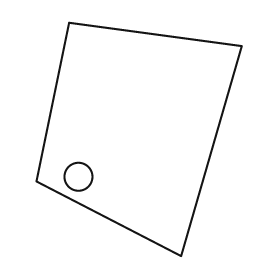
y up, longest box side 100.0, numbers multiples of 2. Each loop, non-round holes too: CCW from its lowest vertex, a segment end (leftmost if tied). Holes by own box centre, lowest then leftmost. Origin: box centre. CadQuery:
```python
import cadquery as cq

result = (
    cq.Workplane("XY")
    .moveTo(18.0, -50.0)
    .lineTo(44.0, 40.0)
    .lineTo(-30.0, 50.0)
    .lineTo(-44.0, -18.0)
    .close()
    .moveTo(-26.0, -16.0)
    .circle(6.0)
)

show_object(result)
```